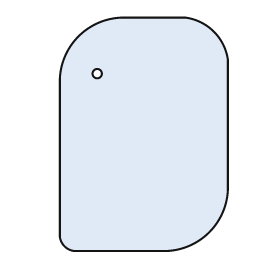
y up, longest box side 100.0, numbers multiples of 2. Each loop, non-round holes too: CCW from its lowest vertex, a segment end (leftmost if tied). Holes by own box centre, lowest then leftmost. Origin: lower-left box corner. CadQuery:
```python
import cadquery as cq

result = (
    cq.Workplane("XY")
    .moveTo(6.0, 0.0)
    .lineTo(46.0, 0.0)
    .threePointArc((64.0, 8.0), (72.0, 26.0))
    .lineTo(72.0, 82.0)
    .threePointArc((66.0, 94.0), (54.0, 100.0))
    .lineTo(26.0, 100.0)
    .threePointArc((8.0, 92.0), (0.0, 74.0))
    .lineTo(0.0, 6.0)
    .threePointArc((2.0, 2.0), (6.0, 0.0))
    .close()
    .moveTo(16.0, 76.0)
    .circle(2.0)
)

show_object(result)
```